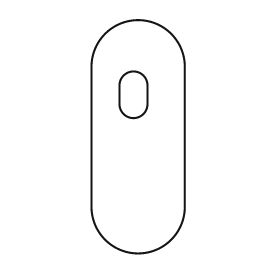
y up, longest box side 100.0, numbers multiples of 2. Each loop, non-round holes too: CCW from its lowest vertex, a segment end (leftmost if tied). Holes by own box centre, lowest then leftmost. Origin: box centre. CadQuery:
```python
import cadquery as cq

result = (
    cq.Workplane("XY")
    .moveTo(-20.0, -30.0)
    .threePointArc((0.0, -50.0), (20.0, -30.0))
    .lineTo(20.0, 30.0)
    .threePointArc((0.0, 50.0), (-20.0, 30.0))
    .close()
    .moveTo(-8.0, 14.0)
    .threePointArc((-2.0, 8.0), (4.0, 14.0))
    .lineTo(4.0, 22.0)
    .threePointArc((-2.0, 28.0), (-8.0, 22.0))
    .close()
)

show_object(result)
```